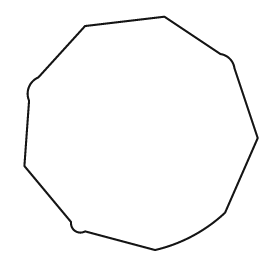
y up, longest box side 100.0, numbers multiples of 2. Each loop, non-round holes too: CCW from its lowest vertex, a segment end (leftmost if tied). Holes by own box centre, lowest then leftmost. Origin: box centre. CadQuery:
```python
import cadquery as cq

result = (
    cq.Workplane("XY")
    .moveTo(6.0, -50.0)
    .threePointArc((22.0, -44.0), (36.0, -34.0))
    .lineTo(50.0, -2.0)
    .lineTo(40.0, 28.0)
    .threePointArc((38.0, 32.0), (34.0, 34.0))
    .lineTo(10.0, 50.0)
    .lineTo(-24.0, 46.0)
    .lineTo(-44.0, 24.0)
    .threePointArc((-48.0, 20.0), (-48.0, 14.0))
    .lineTo(-50.0, -14.0)
    .lineTo(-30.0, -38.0)
    .threePointArc((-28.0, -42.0), (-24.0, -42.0))
    .close()
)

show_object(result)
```